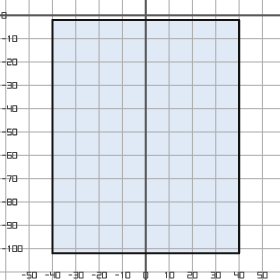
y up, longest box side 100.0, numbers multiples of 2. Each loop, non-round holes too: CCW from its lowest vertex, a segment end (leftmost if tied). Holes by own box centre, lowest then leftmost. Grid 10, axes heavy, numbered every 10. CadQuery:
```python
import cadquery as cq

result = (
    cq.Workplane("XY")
    .moveTo(-40.0, -102.0)
    .lineTo(40.0, -102.0)
    .lineTo(40.0, -2.0)
    .lineTo(-40.0, -2.0)
    .close()
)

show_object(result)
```